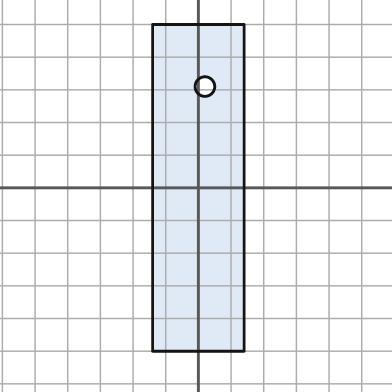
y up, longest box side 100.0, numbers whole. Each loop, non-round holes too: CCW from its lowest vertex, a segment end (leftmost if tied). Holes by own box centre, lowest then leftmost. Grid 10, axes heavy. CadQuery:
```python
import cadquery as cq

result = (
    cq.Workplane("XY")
    .moveTo(-14.0, -50.0)
    .lineTo(14.0, -50.0)
    .lineTo(14.0, 50.0)
    .lineTo(-14.0, 50.0)
    .close()
    .moveTo(2.0, 31.0)
    .circle(3.0)
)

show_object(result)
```